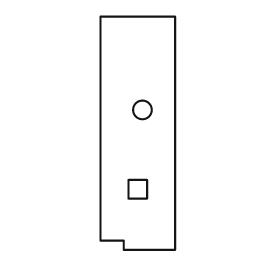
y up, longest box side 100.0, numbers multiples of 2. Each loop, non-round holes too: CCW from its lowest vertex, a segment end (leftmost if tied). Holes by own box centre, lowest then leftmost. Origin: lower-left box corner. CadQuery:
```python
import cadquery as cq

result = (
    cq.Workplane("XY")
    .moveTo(10.0, 0.0)
    .lineTo(32.0, 0.0)
    .lineTo(32.0, 100.0)
    .lineTo(0.0, 100.0)
    .lineTo(0.0, 4.0)
    .lineTo(10.0, 4.0)
    .close()
    .moveTo(12.0, 22.0)
    .lineTo(20.0, 22.0)
    .lineTo(20.0, 30.0)
    .lineTo(12.0, 30.0)
    .close()
    .moveTo(18.0, 60.0)
    .circle(4.0)
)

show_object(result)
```